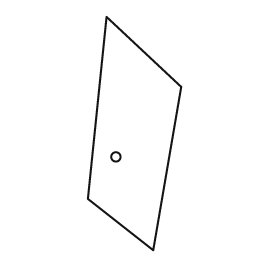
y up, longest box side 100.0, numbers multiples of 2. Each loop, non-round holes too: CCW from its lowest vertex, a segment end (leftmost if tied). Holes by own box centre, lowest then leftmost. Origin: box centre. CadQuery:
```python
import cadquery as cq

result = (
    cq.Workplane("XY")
    .moveTo(8.0, -50.0)
    .lineTo(20.0, 20.0)
    .lineTo(-12.0, 50.0)
    .lineTo(-20.0, -28.0)
    .close()
    .moveTo(-8.0, -10.0)
    .circle(2.0)
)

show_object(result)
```